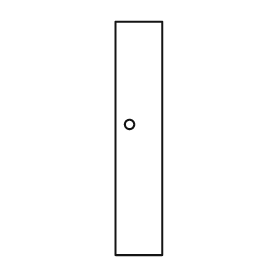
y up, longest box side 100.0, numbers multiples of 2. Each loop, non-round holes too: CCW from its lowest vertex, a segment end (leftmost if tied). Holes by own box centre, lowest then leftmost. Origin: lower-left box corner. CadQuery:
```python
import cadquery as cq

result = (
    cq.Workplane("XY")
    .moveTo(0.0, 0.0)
    .lineTo(20.0, 0.0)
    .lineTo(20.0, 100.0)
    .lineTo(0.0, 100.0)
    .close()
    .moveTo(6.0, 56.0)
    .circle(2.0)
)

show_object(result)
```